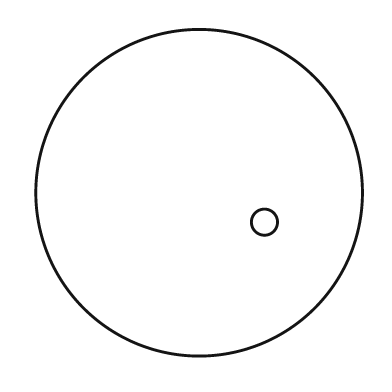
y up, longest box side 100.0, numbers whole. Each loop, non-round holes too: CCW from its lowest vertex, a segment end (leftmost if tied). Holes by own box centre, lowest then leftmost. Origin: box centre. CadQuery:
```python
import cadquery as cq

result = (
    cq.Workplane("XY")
    .moveTo(0.0, 0.0)
    .circle(50.0)
    .moveTo(20.0, -9.0)
    .circle(4.0)
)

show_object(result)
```